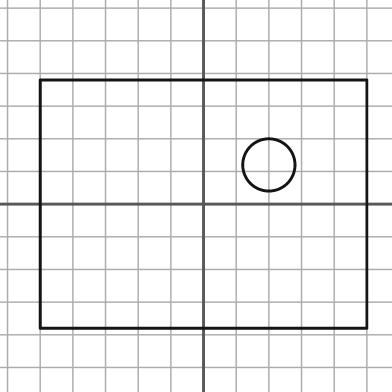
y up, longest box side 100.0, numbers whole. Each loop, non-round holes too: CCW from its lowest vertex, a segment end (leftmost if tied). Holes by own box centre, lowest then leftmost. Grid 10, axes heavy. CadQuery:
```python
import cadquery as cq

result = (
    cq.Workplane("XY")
    .moveTo(-50.0, -38.0)
    .lineTo(50.0, -38.0)
    .lineTo(50.0, 38.0)
    .lineTo(-50.0, 38.0)
    .close()
    .moveTo(20.0, 12.0)
    .circle(8.0)
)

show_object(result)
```